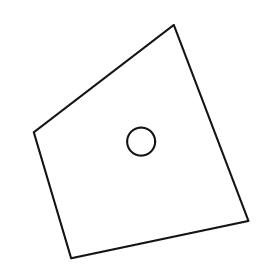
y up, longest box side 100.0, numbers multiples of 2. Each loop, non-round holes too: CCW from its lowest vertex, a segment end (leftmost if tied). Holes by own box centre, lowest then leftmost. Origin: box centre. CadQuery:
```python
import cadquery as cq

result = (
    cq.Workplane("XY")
    .moveTo(-30.0, -50.0)
    .lineTo(46.0, -34.0)
    .lineTo(14.0, 50.0)
    .lineTo(-46.0, 4.0)
    .close()
    .moveTo(0.0, 0.0)
    .circle(6.0)
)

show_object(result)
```